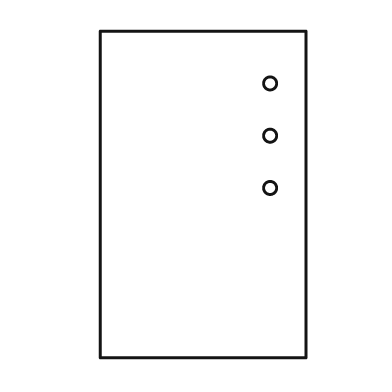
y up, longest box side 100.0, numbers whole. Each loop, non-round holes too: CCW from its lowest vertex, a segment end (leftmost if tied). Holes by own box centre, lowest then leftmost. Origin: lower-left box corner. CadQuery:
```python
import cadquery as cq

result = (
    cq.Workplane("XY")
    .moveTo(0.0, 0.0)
    .lineTo(63.0, 0.0)
    .lineTo(63.0, 100.0)
    .lineTo(0.0, 100.0)
    .close()
    .moveTo(52.0, 52.0)
    .circle(2.0)
    .moveTo(52.0, 68.0)
    .circle(2.0)
    .moveTo(52.0, 84.0)
    .circle(2.0)
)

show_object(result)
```